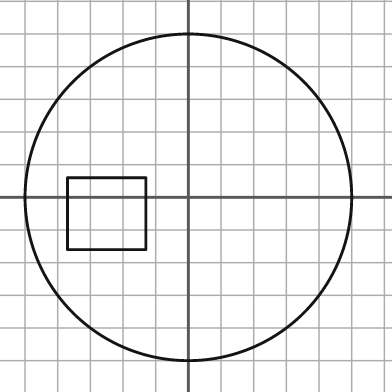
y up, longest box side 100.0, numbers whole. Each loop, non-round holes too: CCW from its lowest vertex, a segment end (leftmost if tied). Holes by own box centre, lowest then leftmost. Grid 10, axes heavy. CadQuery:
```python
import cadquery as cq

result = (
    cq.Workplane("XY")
    .moveTo(0.0, 0.0)
    .circle(50.0)
    .moveTo(-37.0, -16.0)
    .lineTo(-13.0, -16.0)
    .lineTo(-13.0, 6.0)
    .lineTo(-37.0, 6.0)
    .close()
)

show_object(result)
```